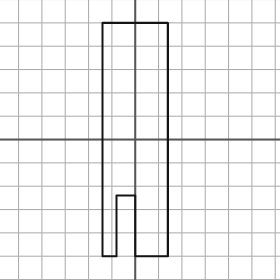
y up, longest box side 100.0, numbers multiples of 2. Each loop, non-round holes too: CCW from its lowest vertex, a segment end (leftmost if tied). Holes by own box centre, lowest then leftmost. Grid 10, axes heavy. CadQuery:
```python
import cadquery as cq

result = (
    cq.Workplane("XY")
    .moveTo(-14.0, -50.0)
    .lineTo(-8.0, -50.0)
    .lineTo(-8.0, -24.0)
    .lineTo(0.0, -24.0)
    .lineTo(0.0, -50.0)
    .lineTo(14.0, -50.0)
    .lineTo(14.0, 50.0)
    .lineTo(-14.0, 50.0)
    .close()
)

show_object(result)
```